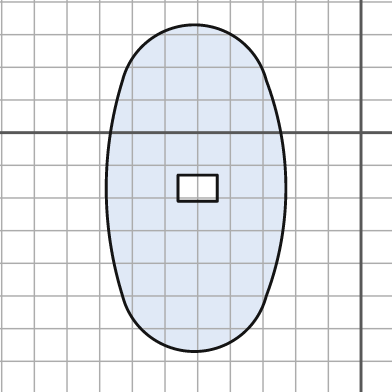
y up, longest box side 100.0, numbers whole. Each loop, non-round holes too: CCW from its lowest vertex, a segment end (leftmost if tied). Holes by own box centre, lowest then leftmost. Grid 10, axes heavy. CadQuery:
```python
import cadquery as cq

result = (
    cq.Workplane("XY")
    .moveTo(-73.0, -50.0)
    .threePointArc((-51.0, -67.0), (-29.0, -50.0))
    .threePointArc((-23.0, -17.0), (-29.0, 16.0))
    .threePointArc((-51.0, 33.0), (-73.0, 16.0))
    .threePointArc((-78.0, -17.0), (-73.0, -50.0))
    .close()
    .moveTo(-56.0, -21.0)
    .lineTo(-44.0, -21.0)
    .lineTo(-44.0, -13.0)
    .lineTo(-56.0, -13.0)
    .close()
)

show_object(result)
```